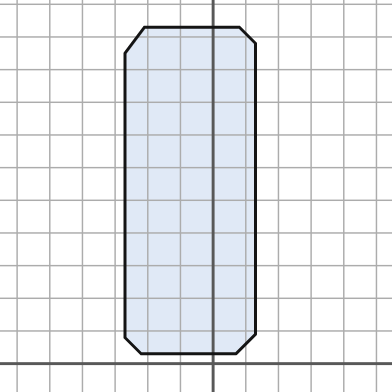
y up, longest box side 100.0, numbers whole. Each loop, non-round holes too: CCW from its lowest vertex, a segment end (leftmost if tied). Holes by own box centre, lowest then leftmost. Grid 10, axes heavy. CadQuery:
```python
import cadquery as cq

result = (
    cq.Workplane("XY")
    .moveTo(-22.0, 3.0)
    .lineTo(7.0, 3.0)
    .lineTo(13.0, 9.0)
    .lineTo(13.0, 98.0)
    .lineTo(8.0, 103.0)
    .lineTo(-21.0, 103.0)
    .lineTo(-27.0, 95.0)
    .lineTo(-27.0, 8.0)
    .close()
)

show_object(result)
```